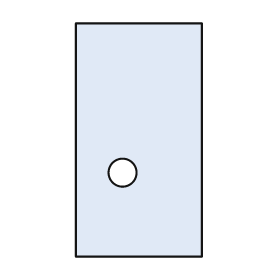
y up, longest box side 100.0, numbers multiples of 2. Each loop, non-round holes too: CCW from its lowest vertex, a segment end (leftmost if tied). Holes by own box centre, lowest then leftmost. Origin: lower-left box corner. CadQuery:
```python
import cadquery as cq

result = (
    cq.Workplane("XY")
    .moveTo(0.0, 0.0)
    .lineTo(54.0, 0.0)
    .lineTo(54.0, 100.0)
    .lineTo(0.0, 100.0)
    .close()
    .moveTo(20.0, 36.0)
    .circle(6.0)
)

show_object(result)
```